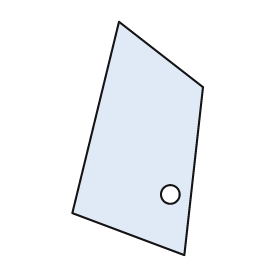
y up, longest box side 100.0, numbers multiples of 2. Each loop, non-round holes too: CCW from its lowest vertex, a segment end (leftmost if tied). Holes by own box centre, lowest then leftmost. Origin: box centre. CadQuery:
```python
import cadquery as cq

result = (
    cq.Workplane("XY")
    .moveTo(20.0, -50.0)
    .lineTo(28.0, 22.0)
    .lineTo(-8.0, 50.0)
    .lineTo(-28.0, -32.0)
    .close()
    .moveTo(14.0, -24.0)
    .circle(4.0)
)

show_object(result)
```